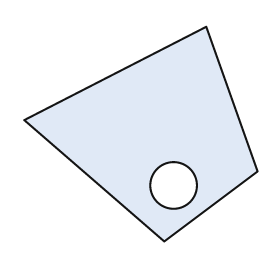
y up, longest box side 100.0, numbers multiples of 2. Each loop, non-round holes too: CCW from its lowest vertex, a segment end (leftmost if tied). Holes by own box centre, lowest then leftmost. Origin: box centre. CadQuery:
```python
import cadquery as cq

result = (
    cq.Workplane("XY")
    .moveTo(10.0, -46.0)
    .lineTo(50.0, -16.0)
    .lineTo(28.0, 46.0)
    .lineTo(-50.0, 6.0)
    .close()
    .moveTo(14.0, -22.0)
    .circle(10.0)
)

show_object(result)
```